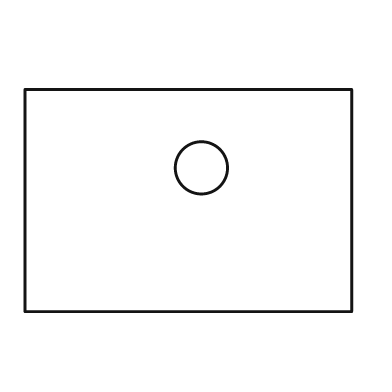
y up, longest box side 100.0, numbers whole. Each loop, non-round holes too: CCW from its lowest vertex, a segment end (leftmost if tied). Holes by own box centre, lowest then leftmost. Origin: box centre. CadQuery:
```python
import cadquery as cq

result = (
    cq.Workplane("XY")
    .moveTo(-50.0, -34.0)
    .lineTo(50.0, -34.0)
    .lineTo(50.0, 34.0)
    .lineTo(-50.0, 34.0)
    .close()
    .moveTo(4.0, 10.0)
    .circle(8.0)
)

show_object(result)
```